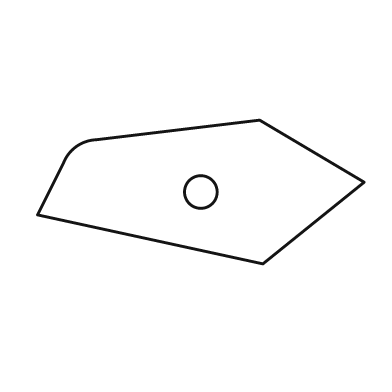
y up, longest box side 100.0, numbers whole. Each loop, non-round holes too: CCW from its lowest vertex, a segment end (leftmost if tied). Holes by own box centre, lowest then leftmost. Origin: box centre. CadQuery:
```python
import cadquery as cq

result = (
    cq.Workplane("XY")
    .moveTo(19.0, -22.0)
    .lineTo(50.0, 3.0)
    .lineTo(18.0, 22.0)
    .lineTo(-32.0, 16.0)
    .threePointArc((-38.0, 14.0), (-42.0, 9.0))
    .lineTo(-50.0, -7.0)
    .close()
    .moveTo(0.0, 0.0)
    .circle(5.0)
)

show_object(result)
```